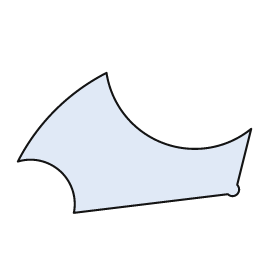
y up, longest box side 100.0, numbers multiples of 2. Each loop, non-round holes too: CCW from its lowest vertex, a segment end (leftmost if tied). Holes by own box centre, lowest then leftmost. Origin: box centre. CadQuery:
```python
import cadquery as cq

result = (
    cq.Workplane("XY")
    .moveTo(-26.0, -30.0)
    .lineTo(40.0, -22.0)
    .threePointArc((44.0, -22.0), (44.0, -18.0))
    .lineTo(50.0, 6.0)
    .threePointArc((12.0, 0.0), (-12.0, 30.0))
    .threePointArc((-34.0, 14.0), (-50.0, -8.0))
    .threePointArc((-32.0, -12.0), (-26.0, -30.0))
    .close()
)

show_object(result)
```